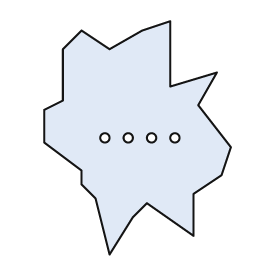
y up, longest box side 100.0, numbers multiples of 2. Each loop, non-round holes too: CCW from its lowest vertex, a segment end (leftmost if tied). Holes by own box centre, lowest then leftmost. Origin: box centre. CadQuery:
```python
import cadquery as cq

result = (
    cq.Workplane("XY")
    .moveTo(-12.0, -50.0)
    .lineTo(-2.0, -34.0)
    .lineTo(4.0, -28.0)
    .lineTo(24.0, -42.0)
    .lineTo(24.0, -24.0)
    .lineTo(36.0, -16.0)
    .lineTo(40.0, -4.0)
    .lineTo(26.0, 14.0)
    .lineTo(34.0, 28.0)
    .lineTo(14.0, 22.0)
    .lineTo(14.0, 50.0)
    .lineTo(2.0, 46.0)
    .lineTo(-12.0, 38.0)
    .lineTo(-24.0, 46.0)
    .lineTo(-32.0, 38.0)
    .lineTo(-32.0, 16.0)
    .lineTo(-40.0, 12.0)
    .lineTo(-40.0, -2.0)
    .lineTo(-24.0, -14.0)
    .lineTo(-24.0, -20.0)
    .lineTo(-18.0, -26.0)
    .close()
    .moveTo(-14.0, 0.0)
    .circle(2.0)
    .moveTo(-4.0, 0.0)
    .circle(2.0)
    .moveTo(6.0, 0.0)
    .circle(2.0)
    .moveTo(16.0, 0.0)
    .circle(2.0)
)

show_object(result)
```